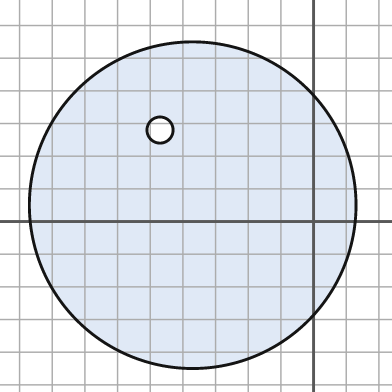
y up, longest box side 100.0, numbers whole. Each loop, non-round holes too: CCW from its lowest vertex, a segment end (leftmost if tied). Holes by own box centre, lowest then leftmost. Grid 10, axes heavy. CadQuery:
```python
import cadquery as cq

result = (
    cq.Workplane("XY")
    .moveTo(-37.0, 5.0)
    .circle(50.0)
    .moveTo(-47.0, 28.0)
    .circle(4.0)
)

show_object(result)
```